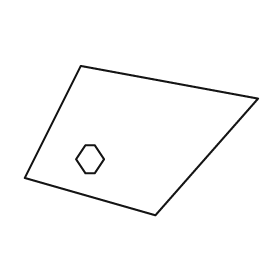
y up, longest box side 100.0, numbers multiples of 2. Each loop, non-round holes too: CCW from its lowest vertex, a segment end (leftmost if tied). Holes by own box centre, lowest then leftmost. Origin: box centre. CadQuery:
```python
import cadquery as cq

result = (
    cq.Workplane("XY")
    .moveTo(6.0, -32.0)
    .lineTo(50.0, 18.0)
    .lineTo(-26.0, 32.0)
    .lineTo(-50.0, -16.0)
    .close()
    .moveTo(-24.0, -14.0)
    .lineTo(-20.0, -14.0)
    .lineTo(-16.0, -8.0)
    .lineTo(-20.0, -2.0)
    .lineTo(-24.0, -2.0)
    .lineTo(-28.0, -8.0)
    .close()
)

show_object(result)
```